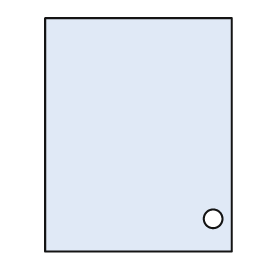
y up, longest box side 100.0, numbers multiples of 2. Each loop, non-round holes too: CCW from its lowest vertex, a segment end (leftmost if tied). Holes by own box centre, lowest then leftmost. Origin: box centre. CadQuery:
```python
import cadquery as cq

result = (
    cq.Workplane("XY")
    .moveTo(-40.0, -50.0)
    .lineTo(40.0, -50.0)
    .lineTo(40.0, 50.0)
    .lineTo(-40.0, 50.0)
    .close()
    .moveTo(32.0, -36.0)
    .circle(4.0)
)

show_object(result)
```